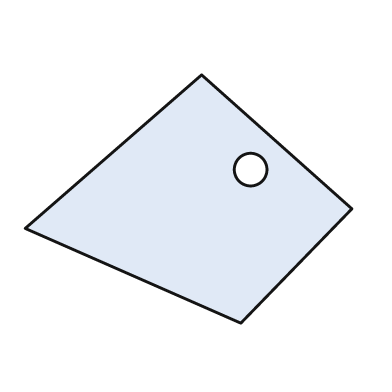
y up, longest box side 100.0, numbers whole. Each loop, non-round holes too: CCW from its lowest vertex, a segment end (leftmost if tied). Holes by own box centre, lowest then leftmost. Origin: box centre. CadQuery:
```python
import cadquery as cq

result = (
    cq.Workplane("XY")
    .moveTo(16.0, -38.0)
    .lineTo(50.0, -3.0)
    .lineTo(4.0, 38.0)
    .lineTo(-50.0, -9.0)
    .close()
    .moveTo(19.0, 9.0)
    .circle(5.0)
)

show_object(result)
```